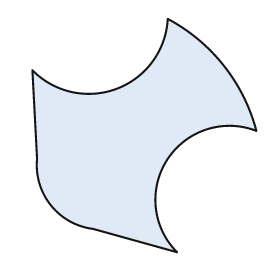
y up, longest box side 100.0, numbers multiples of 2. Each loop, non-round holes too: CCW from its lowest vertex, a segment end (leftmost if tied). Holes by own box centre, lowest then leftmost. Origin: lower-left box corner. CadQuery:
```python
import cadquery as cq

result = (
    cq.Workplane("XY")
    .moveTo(62.0, 0.0)
    .threePointArc((58.0, 40.0), (96.0, 52.0))
    .threePointArc((82.0, 80.0), (58.0, 100.0))
    .threePointArc((36.0, 70.0), (0.0, 78.0))
    .lineTo(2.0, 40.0)
    .threePointArc((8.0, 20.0), (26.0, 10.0))
    .close()
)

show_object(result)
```